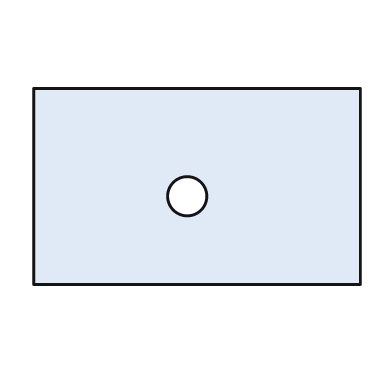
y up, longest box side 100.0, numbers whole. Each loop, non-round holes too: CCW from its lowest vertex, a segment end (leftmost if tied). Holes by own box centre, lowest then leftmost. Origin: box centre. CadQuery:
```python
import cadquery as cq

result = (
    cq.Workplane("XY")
    .moveTo(-50.0, -30.0)
    .lineTo(50.0, -30.0)
    .lineTo(50.0, 30.0)
    .lineTo(-50.0, 30.0)
    .close()
    .moveTo(-3.0, -3.0)
    .circle(6.0)
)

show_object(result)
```